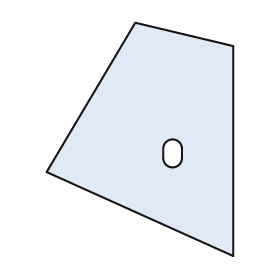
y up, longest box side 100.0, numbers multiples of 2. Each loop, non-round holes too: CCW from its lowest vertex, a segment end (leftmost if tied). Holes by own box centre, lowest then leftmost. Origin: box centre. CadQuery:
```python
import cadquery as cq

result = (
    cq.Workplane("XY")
    .moveTo(40.0, -50.0)
    .lineTo(40.0, 40.0)
    .lineTo(-2.0, 50.0)
    .lineTo(-40.0, -14.0)
    .close()
    .moveTo(10.0, -8.0)
    .threePointArc((14.0, -12.0), (18.0, -8.0))
    .lineTo(18.0, -4.0)
    .threePointArc((14.0, 0.0), (10.0, -4.0))
    .close()
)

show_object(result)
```